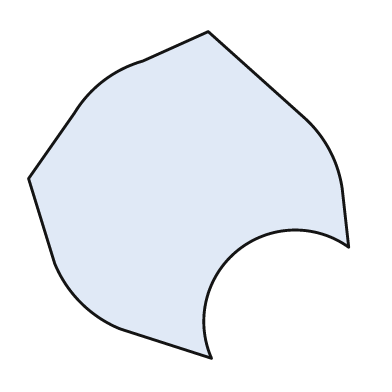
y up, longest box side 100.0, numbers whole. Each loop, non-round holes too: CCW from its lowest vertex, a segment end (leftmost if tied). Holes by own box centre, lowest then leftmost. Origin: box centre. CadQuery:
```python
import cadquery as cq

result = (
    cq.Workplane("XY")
    .moveTo(7.0, -50.0)
    .threePointArc((15.0, -17.0), (49.0, -16.0))
    .lineTo(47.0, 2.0)
    .threePointArc((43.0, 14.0), (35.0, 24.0))
    .lineTo(6.0, 50.0)
    .lineTo(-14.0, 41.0)
    .threePointArc((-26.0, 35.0), (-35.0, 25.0))
    .lineTo(-49.0, 5.0)
    .lineTo(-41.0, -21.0)
    .threePointArc((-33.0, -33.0), (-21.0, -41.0))
    .close()
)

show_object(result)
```